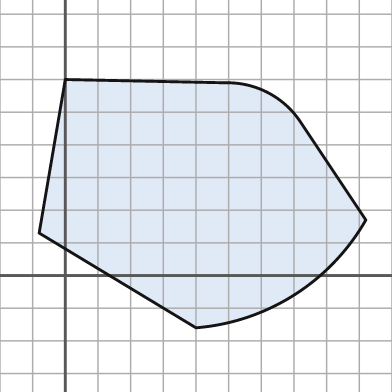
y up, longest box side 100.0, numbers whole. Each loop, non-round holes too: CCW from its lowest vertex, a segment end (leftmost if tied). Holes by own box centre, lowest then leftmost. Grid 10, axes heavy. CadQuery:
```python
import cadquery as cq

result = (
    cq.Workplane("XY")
    .moveTo(40.0, -16.0)
    .threePointArc((70.0, -6.0), (92.0, 17.0))
    .lineTo(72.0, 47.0)
    .threePointArc((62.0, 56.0), (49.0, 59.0))
    .lineTo(0.0, 60.0)
    .lineTo(-8.0, 13.0)
    .close()
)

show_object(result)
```